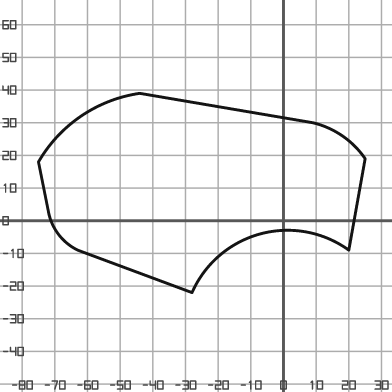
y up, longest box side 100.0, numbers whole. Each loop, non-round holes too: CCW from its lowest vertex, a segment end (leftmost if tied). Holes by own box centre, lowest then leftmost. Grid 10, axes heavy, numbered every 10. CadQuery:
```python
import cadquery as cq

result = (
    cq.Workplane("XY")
    .moveTo(-28.0, -22.0)
    .threePointArc((-7.0, -4.0), (20.0, -9.0))
    .lineTo(25.0, 19.0)
    .threePointArc((18.0, 26.0), (9.0, 30.0))
    .lineTo(-44.0, 39.0)
    .threePointArc((-62.0, 32.0), (-75.0, 18.0))
    .lineTo(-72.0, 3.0)
    .threePointArc((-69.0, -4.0), (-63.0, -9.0))
    .close()
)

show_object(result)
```